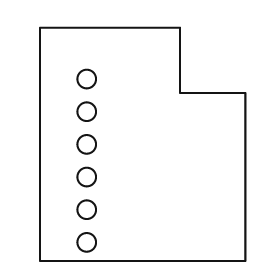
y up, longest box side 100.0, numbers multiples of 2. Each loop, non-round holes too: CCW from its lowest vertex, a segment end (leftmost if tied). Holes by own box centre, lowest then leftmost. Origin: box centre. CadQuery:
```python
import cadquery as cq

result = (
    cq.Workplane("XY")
    .moveTo(-44.0, -50.0)
    .lineTo(44.0, -50.0)
    .lineTo(44.0, 22.0)
    .lineTo(16.0, 22.0)
    .lineTo(16.0, 50.0)
    .lineTo(-44.0, 50.0)
    .close()
    .moveTo(-24.0, -42.0)
    .circle(4.0)
    .moveTo(-24.0, -28.0)
    .circle(4.0)
    .moveTo(-24.0, -14.0)
    .circle(4.0)
    .moveTo(-24.0, 0.0)
    .circle(4.0)
    .moveTo(-24.0, 14.0)
    .circle(4.0)
    .moveTo(-24.0, 28.0)
    .circle(4.0)
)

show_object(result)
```